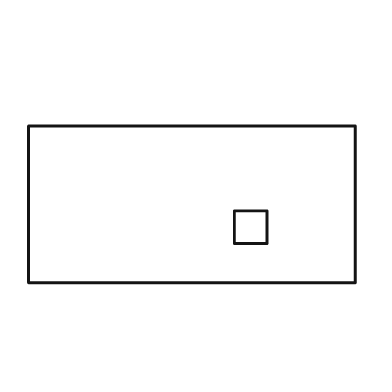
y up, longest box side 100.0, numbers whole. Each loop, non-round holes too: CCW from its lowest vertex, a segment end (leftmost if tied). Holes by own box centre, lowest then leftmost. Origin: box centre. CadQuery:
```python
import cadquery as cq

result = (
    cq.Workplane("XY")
    .moveTo(-50.0, -24.0)
    .lineTo(50.0, -24.0)
    .lineTo(50.0, 24.0)
    .lineTo(-50.0, 24.0)
    .close()
    .moveTo(13.0, -12.0)
    .lineTo(23.0, -12.0)
    .lineTo(23.0, -2.0)
    .lineTo(13.0, -2.0)
    .close()
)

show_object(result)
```